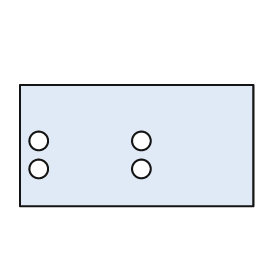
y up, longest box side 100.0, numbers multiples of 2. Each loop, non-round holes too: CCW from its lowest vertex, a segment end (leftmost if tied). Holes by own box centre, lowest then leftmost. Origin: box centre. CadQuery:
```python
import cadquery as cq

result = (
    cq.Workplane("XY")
    .moveTo(-50.0, -26.0)
    .lineTo(50.0, -26.0)
    .lineTo(50.0, 26.0)
    .lineTo(-50.0, 26.0)
    .close()
    .moveTo(-42.0, -10.0)
    .circle(4.0)
    .moveTo(2.0, -10.0)
    .circle(4.0)
    .moveTo(-42.0, 2.0)
    .circle(4.0)
    .moveTo(2.0, 2.0)
    .circle(4.0)
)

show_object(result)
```